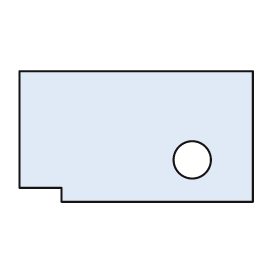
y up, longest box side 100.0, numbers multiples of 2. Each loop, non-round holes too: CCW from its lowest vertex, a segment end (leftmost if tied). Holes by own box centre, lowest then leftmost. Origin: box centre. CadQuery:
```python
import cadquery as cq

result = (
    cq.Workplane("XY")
    .moveTo(-32.0, -28.0)
    .lineTo(50.0, -28.0)
    .lineTo(50.0, 28.0)
    .lineTo(-50.0, 28.0)
    .lineTo(-50.0, -22.0)
    .lineTo(-32.0, -22.0)
    .close()
    .moveTo(24.0, -10.0)
    .circle(8.0)
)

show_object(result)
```